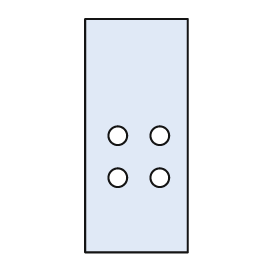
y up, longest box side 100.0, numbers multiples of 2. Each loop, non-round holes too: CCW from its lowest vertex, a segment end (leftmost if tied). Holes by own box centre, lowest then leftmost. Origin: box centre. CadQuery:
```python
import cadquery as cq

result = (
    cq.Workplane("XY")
    .moveTo(-22.0, -50.0)
    .lineTo(22.0, -50.0)
    .lineTo(22.0, 50.0)
    .lineTo(-22.0, 50.0)
    .close()
    .moveTo(-8.0, -18.0)
    .circle(4.0)
    .moveTo(10.0, -18.0)
    .circle(4.0)
    .moveTo(-8.0, 0.0)
    .circle(4.0)
    .moveTo(10.0, 0.0)
    .circle(4.0)
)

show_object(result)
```